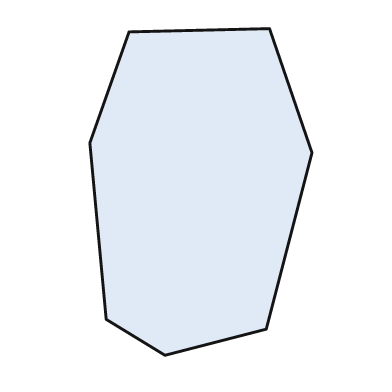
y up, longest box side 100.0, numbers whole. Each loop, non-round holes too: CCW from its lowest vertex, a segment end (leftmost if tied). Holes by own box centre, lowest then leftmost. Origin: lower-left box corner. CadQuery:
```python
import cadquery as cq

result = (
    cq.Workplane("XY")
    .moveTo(23.0, 0.0)
    .lineTo(54.0, 8.0)
    .lineTo(68.0, 62.0)
    .lineTo(55.0, 100.0)
    .lineTo(12.0, 99.0)
    .lineTo(0.0, 65.0)
    .lineTo(5.0, 11.0)
    .close()
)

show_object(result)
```